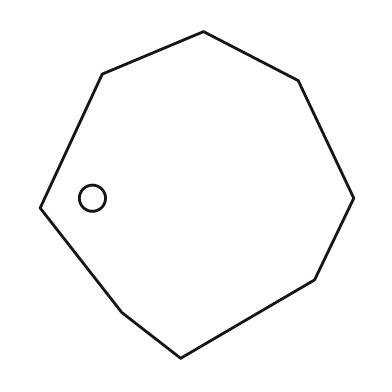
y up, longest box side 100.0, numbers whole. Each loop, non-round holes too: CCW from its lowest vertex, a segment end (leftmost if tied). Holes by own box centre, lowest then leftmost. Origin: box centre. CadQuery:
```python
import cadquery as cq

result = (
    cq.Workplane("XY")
    .moveTo(-5.0, -50.0)
    .lineTo(36.0, -26.0)
    .lineTo(48.0, -1.0)
    .lineTo(31.0, 35.0)
    .lineTo(2.0, 50.0)
    .lineTo(-29.0, 37.0)
    .lineTo(-48.0, -4.0)
    .lineTo(-23.0, -36.0)
    .close()
    .moveTo(-32.0, -1.0)
    .circle(4.0)
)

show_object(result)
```